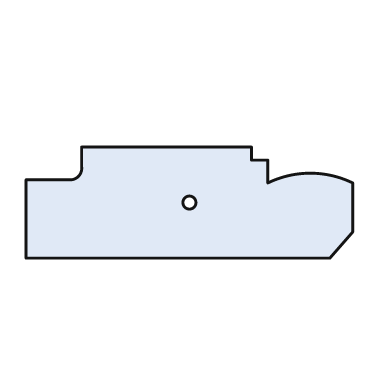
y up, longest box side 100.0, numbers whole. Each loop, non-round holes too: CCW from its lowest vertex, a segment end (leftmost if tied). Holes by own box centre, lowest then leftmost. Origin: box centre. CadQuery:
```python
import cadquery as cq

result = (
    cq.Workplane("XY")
    .moveTo(-50.0, -17.0)
    .lineTo(43.0, -17.0)
    .lineTo(50.0, -9.0)
    .lineTo(50.0, 6.0)
    .threePointArc((37.0, 9.0), (24.0, 6.0))
    .lineTo(24.0, 13.0)
    .lineTo(19.0, 13.0)
    .lineTo(19.0, 17.0)
    .lineTo(-33.0, 17.0)
    .lineTo(-33.0, 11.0)
    .threePointArc((-34.0, 8.0), (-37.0, 7.0))
    .lineTo(-50.0, 7.0)
    .close()
    .moveTo(0.0, 0.0)
    .circle(2.0)
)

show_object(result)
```